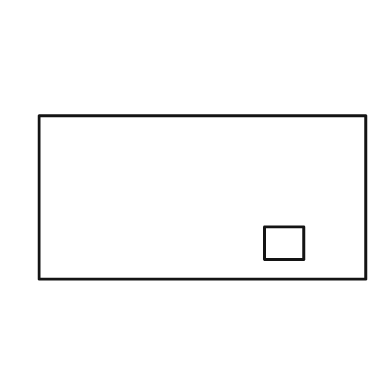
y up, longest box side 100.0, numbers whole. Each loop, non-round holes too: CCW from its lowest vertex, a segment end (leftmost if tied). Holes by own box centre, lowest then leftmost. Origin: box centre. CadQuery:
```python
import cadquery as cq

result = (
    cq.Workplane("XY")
    .moveTo(-50.0, -25.0)
    .lineTo(50.0, -25.0)
    .lineTo(50.0, 25.0)
    .lineTo(-50.0, 25.0)
    .close()
    .moveTo(19.0, -19.0)
    .lineTo(31.0, -19.0)
    .lineTo(31.0, -9.0)
    .lineTo(19.0, -9.0)
    .close()
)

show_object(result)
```